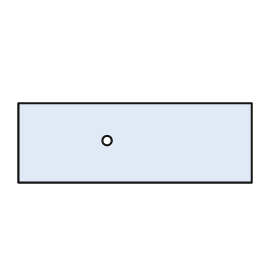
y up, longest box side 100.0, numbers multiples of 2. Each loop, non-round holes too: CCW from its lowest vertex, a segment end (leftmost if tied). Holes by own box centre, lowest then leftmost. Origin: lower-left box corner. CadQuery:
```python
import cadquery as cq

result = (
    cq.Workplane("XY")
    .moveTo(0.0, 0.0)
    .lineTo(100.0, 0.0)
    .lineTo(100.0, 34.0)
    .lineTo(0.0, 34.0)
    .close()
    .moveTo(38.0, 18.0)
    .circle(2.0)
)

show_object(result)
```